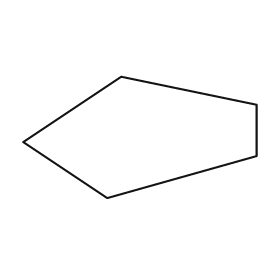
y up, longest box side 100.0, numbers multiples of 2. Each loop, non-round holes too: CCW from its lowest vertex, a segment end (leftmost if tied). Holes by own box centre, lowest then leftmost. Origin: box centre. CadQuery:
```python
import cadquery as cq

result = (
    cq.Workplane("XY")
    .moveTo(-14.0, -26.0)
    .lineTo(50.0, -8.0)
    .lineTo(50.0, 14.0)
    .lineTo(-8.0, 26.0)
    .lineTo(-50.0, -2.0)
    .close()
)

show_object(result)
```